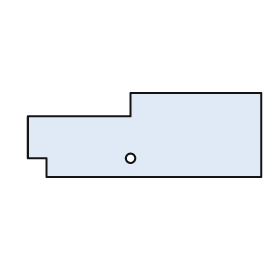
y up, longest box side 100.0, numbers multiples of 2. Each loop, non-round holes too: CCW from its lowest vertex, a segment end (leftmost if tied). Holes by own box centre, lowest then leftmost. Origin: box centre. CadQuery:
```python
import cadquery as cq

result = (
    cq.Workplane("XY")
    .moveTo(-42.0, -18.0)
    .lineTo(50.0, -18.0)
    .lineTo(50.0, 18.0)
    .lineTo(-6.0, 18.0)
    .lineTo(-6.0, 8.0)
    .lineTo(-50.0, 8.0)
    .lineTo(-50.0, -10.0)
    .lineTo(-42.0, -10.0)
    .close()
    .moveTo(-6.0, -10.0)
    .circle(2.0)
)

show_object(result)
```